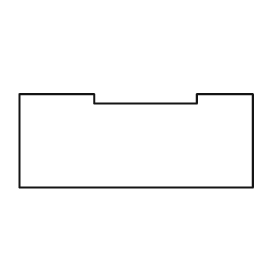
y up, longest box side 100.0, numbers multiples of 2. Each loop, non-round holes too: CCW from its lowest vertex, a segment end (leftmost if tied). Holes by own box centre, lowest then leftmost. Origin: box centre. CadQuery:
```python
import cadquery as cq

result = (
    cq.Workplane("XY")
    .moveTo(-50.0, -20.0)
    .lineTo(50.0, -20.0)
    .lineTo(50.0, 20.0)
    .lineTo(26.0, 20.0)
    .lineTo(26.0, 16.0)
    .lineTo(-18.0, 16.0)
    .lineTo(-18.0, 20.0)
    .lineTo(-50.0, 20.0)
    .close()
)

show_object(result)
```